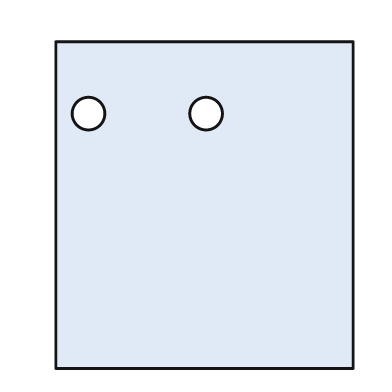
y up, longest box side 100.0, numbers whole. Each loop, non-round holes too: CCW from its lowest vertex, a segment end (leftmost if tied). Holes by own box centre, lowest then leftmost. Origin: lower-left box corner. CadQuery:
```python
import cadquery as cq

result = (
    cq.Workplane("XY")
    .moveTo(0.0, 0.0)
    .lineTo(91.0, 0.0)
    .lineTo(91.0, 100.0)
    .lineTo(0.0, 100.0)
    .close()
    .moveTo(10.0, 78.0)
    .circle(5.0)
    .moveTo(46.0, 78.0)
    .circle(5.0)
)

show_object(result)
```